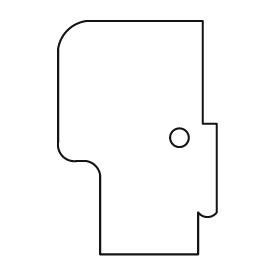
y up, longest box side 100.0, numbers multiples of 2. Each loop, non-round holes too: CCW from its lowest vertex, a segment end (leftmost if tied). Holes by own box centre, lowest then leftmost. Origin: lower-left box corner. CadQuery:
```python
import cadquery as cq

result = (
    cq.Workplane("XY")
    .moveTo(18.0, 0.0)
    .lineTo(60.0, 0.0)
    .lineTo(60.0, 18.0)
    .threePointArc((64.0, 16.0), (68.0, 18.0))
    .lineTo(68.0, 56.0)
    .lineTo(62.0, 56.0)
    .lineTo(62.0, 100.0)
    .lineTo(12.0, 100.0)
    .threePointArc((4.0, 96.0), (0.0, 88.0))
    .lineTo(0.0, 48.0)
    .threePointArc((2.0, 42.0), (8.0, 40.0))
    .lineTo(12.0, 40.0)
    .threePointArc((16.0, 38.0), (18.0, 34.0))
    .close()
    .moveTo(52.0, 50.0)
    .circle(4.0)
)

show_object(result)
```